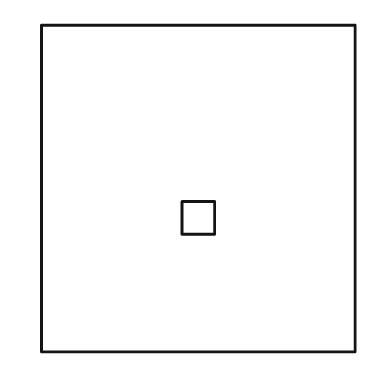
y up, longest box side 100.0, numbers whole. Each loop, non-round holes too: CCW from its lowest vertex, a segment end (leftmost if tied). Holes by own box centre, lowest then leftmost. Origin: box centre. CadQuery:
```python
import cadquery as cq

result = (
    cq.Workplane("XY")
    .moveTo(-48.0, -50.0)
    .lineTo(48.0, -50.0)
    .lineTo(48.0, 50.0)
    .lineTo(-48.0, 50.0)
    .close()
    .moveTo(-5.0, -14.0)
    .lineTo(5.0, -14.0)
    .lineTo(5.0, -4.0)
    .lineTo(-5.0, -4.0)
    .close()
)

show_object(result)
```